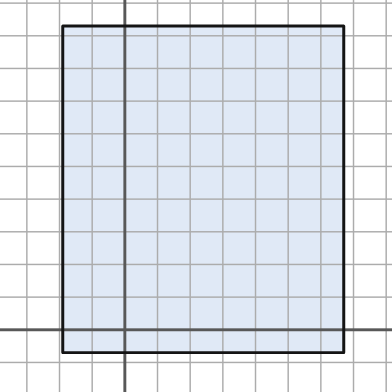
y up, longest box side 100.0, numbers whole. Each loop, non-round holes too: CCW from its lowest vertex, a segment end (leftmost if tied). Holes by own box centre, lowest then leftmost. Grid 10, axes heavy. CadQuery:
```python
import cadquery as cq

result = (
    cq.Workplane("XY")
    .moveTo(-19.0, -7.0)
    .lineTo(67.0, -7.0)
    .lineTo(67.0, 93.0)
    .lineTo(-19.0, 93.0)
    .close()
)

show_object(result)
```